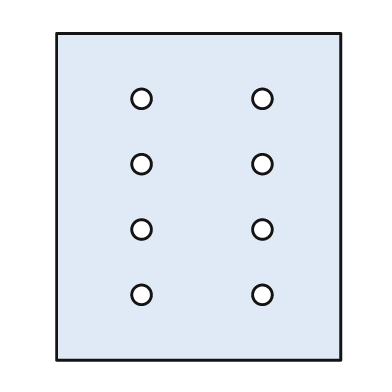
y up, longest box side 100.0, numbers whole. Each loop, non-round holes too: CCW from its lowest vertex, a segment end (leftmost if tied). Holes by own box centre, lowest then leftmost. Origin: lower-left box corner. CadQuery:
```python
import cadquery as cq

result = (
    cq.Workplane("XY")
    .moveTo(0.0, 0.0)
    .lineTo(87.0, 0.0)
    .lineTo(87.0, 100.0)
    .lineTo(0.0, 100.0)
    .close()
    .moveTo(26.0, 20.0)
    .circle(3.0)
    .moveTo(63.0, 20.0)
    .circle(3.0)
    .moveTo(26.0, 40.0)
    .circle(3.0)
    .moveTo(63.0, 40.0)
    .circle(3.0)
    .moveTo(26.0, 60.0)
    .circle(3.0)
    .moveTo(63.0, 60.0)
    .circle(3.0)
    .moveTo(26.0, 80.0)
    .circle(3.0)
    .moveTo(63.0, 80.0)
    .circle(3.0)
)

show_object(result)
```